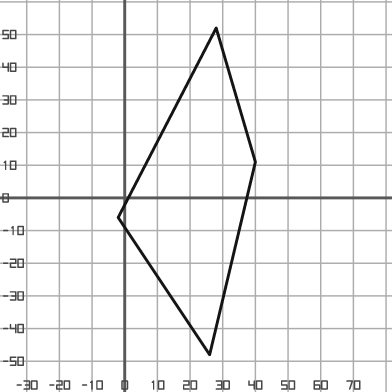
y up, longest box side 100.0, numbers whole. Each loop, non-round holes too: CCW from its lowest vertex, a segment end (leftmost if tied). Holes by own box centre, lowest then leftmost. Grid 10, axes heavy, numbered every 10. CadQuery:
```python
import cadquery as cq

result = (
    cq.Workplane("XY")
    .moveTo(26.0, -48.0)
    .lineTo(40.0, 11.0)
    .lineTo(28.0, 52.0)
    .lineTo(-2.0, -6.0)
    .close()
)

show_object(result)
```